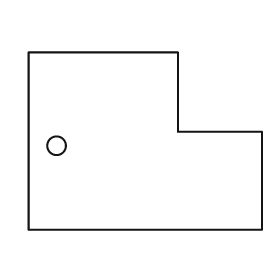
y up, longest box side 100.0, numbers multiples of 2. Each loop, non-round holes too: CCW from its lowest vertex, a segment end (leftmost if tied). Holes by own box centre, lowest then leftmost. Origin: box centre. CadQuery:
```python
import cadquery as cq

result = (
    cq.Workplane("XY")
    .moveTo(-50.0, -38.0)
    .lineTo(50.0, -38.0)
    .lineTo(50.0, 4.0)
    .lineTo(14.0, 4.0)
    .lineTo(14.0, 38.0)
    .lineTo(-50.0, 38.0)
    .close()
    .moveTo(-38.0, -2.0)
    .circle(4.0)
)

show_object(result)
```